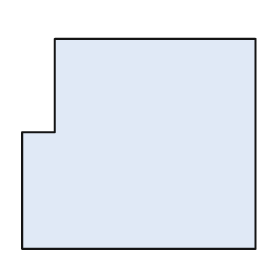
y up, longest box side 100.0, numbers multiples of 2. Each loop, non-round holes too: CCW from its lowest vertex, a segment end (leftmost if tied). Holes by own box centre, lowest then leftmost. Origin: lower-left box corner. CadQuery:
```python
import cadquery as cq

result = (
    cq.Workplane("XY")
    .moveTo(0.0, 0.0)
    .lineTo(100.0, 0.0)
    .lineTo(100.0, 90.0)
    .lineTo(14.0, 90.0)
    .lineTo(14.0, 50.0)
    .lineTo(0.0, 50.0)
    .close()
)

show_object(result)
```